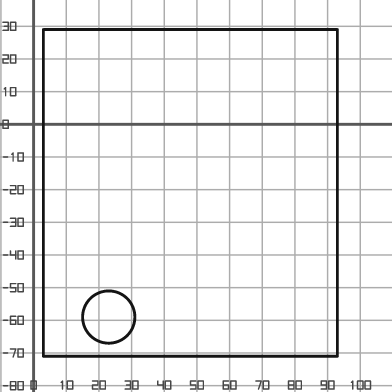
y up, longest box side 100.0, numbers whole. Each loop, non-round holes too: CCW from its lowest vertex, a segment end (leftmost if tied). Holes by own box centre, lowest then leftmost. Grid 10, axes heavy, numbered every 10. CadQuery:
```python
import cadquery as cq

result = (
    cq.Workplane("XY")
    .moveTo(3.0, -71.0)
    .lineTo(93.0, -71.0)
    .lineTo(93.0, 29.0)
    .lineTo(3.0, 29.0)
    .close()
    .moveTo(23.0, -59.0)
    .circle(8.0)
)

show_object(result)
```